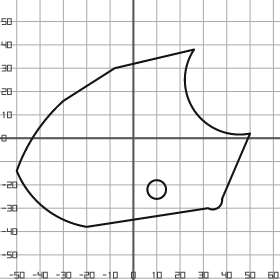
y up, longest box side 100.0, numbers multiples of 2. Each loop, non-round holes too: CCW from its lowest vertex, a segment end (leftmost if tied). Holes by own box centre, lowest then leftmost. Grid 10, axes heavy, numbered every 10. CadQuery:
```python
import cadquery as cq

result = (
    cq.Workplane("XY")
    .moveTo(-20.0, -38.0)
    .lineTo(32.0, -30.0)
    .threePointArc((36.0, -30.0), (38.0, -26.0))
    .lineTo(50.0, 2.0)
    .threePointArc((26.0, 12.0), (26.0, 38.0))
    .lineTo(-8.0, 30.0)
    .lineTo(-30.0, 16.0)
    .threePointArc((-42.0, 2.0), (-50.0, -14.0))
    .threePointArc((-38.0, -30.0), (-20.0, -38.0))
    .close()
    .moveTo(10.0, -22.0)
    .circle(4.0)
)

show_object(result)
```